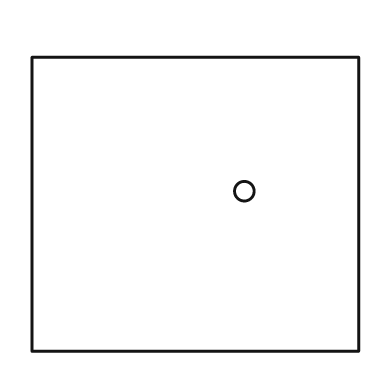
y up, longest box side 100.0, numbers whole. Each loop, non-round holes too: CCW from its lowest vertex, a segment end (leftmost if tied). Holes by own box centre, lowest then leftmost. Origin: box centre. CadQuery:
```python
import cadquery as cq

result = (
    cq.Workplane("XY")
    .moveTo(-50.0, -45.0)
    .lineTo(50.0, -45.0)
    .lineTo(50.0, 45.0)
    .lineTo(-50.0, 45.0)
    .close()
    .moveTo(15.0, 4.0)
    .circle(3.0)
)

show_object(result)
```